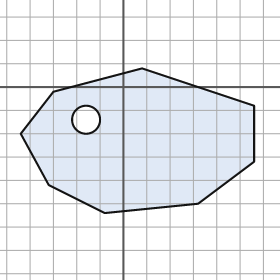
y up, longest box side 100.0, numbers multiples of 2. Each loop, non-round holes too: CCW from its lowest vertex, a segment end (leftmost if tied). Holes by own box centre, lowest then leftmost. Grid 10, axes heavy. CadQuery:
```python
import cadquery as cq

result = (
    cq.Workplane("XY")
    .moveTo(-8.0, -54.0)
    .lineTo(32.0, -50.0)
    .lineTo(56.0, -32.0)
    .lineTo(56.0, -8.0)
    .lineTo(8.0, 8.0)
    .lineTo(-30.0, -2.0)
    .lineTo(-44.0, -20.0)
    .lineTo(-32.0, -42.0)
    .close()
    .moveTo(-16.0, -14.0)
    .circle(6.0)
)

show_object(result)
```